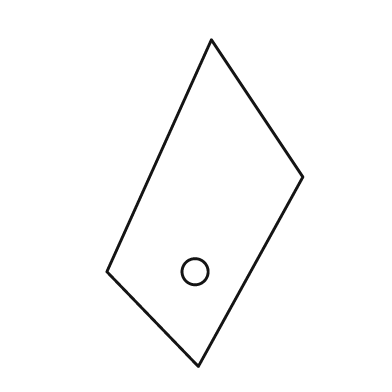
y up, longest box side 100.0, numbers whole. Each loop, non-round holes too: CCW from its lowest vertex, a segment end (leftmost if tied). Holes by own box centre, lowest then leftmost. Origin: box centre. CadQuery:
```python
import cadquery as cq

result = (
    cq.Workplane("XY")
    .moveTo(-2.0, -50.0)
    .lineTo(30.0, 8.0)
    .lineTo(2.0, 50.0)
    .lineTo(-30.0, -21.0)
    .close()
    .moveTo(-3.0, -21.0)
    .circle(4.0)
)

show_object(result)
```